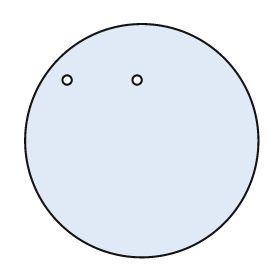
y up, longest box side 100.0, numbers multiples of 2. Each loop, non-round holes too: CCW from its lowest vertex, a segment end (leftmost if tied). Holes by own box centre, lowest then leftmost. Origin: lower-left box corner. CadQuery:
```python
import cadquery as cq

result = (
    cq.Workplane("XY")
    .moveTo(50.0, 50.0)
    .circle(50.0)
    .moveTo(18.0, 76.0)
    .circle(2.0)
    .moveTo(48.0, 76.0)
    .circle(2.0)
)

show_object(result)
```